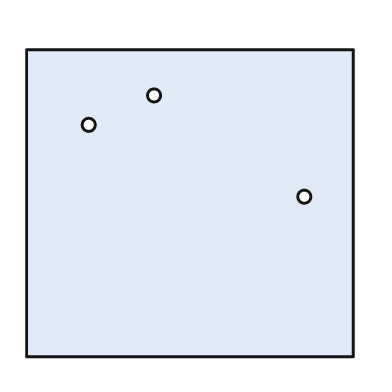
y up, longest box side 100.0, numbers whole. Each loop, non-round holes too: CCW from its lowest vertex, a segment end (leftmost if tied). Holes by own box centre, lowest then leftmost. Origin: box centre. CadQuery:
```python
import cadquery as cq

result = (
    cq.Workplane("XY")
    .moveTo(-50.0, -47.0)
    .lineTo(50.0, -47.0)
    .lineTo(50.0, 47.0)
    .lineTo(-50.0, 47.0)
    .close()
    .moveTo(35.0, 2.0)
    .circle(2.0)
    .moveTo(-31.0, 24.0)
    .circle(2.0)
    .moveTo(-11.0, 33.0)
    .circle(2.0)
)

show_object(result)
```